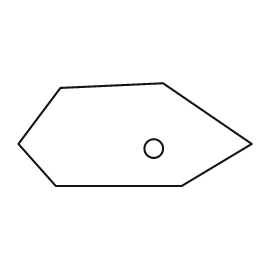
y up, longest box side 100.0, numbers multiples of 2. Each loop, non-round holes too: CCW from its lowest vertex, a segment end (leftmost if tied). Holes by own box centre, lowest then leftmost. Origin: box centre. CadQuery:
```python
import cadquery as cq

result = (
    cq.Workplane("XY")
    .moveTo(-34.0, -22.0)
    .lineTo(20.0, -22.0)
    .lineTo(50.0, -4.0)
    .lineTo(12.0, 22.0)
    .lineTo(-32.0, 20.0)
    .lineTo(-50.0, -4.0)
    .close()
    .moveTo(8.0, -6.0)
    .circle(4.0)
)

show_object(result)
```